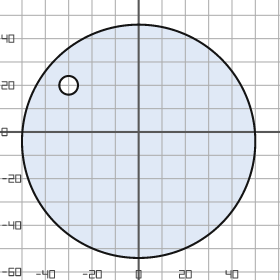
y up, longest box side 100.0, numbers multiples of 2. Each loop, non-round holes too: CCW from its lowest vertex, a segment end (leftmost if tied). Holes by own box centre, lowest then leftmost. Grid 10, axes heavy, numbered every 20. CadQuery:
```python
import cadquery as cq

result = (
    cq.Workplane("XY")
    .moveTo(0.0, -4.0)
    .circle(50.0)
    .moveTo(-30.0, 20.0)
    .circle(4.0)
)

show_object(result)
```